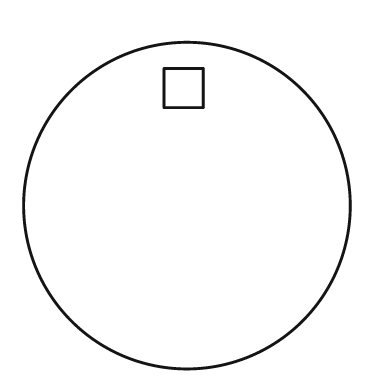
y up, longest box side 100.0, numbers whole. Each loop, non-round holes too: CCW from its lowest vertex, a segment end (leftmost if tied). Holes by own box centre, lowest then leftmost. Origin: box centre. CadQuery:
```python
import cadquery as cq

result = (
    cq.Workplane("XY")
    .moveTo(0.0, 0.0)
    .circle(50.0)
    .moveTo(-7.0, 30.0)
    .lineTo(5.0, 30.0)
    .lineTo(5.0, 42.0)
    .lineTo(-7.0, 42.0)
    .close()
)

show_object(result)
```